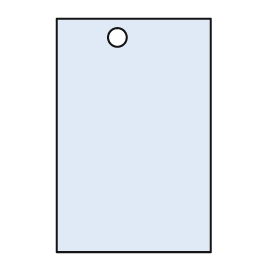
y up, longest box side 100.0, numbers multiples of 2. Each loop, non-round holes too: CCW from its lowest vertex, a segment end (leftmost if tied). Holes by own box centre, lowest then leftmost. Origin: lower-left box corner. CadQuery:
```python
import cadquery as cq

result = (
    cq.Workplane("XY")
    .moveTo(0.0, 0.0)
    .lineTo(66.0, 0.0)
    .lineTo(66.0, 100.0)
    .lineTo(0.0, 100.0)
    .close()
    .moveTo(26.0, 92.0)
    .circle(4.0)
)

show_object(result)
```